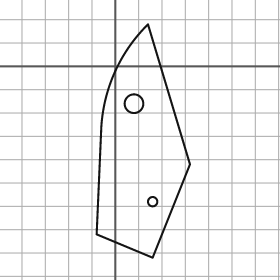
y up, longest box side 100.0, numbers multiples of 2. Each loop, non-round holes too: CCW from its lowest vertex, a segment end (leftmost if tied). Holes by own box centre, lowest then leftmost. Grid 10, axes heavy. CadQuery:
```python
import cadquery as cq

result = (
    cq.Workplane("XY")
    .moveTo(16.0, -82.0)
    .lineTo(32.0, -42.0)
    .lineTo(14.0, 18.0)
    .threePointArc((0.0, -2.0), (-6.0, -26.0))
    .lineTo(-8.0, -72.0)
    .close()
    .moveTo(16.0, -58.0)
    .circle(2.0)
    .moveTo(8.0, -16.0)
    .circle(4.0)
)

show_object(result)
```